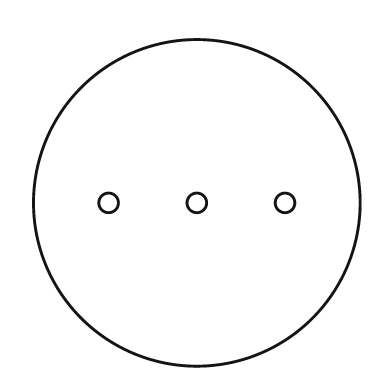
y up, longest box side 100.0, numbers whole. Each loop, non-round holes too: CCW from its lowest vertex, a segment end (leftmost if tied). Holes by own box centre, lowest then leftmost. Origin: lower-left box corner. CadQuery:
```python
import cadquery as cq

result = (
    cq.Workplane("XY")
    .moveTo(50.0, 50.0)
    .circle(50.0)
    .moveTo(23.0, 50.0)
    .circle(3.0)
    .moveTo(50.0, 50.0)
    .circle(3.0)
    .moveTo(77.0, 50.0)
    .circle(3.0)
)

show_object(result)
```